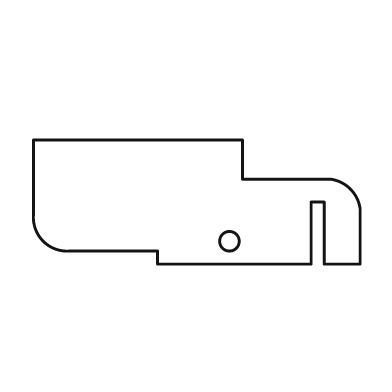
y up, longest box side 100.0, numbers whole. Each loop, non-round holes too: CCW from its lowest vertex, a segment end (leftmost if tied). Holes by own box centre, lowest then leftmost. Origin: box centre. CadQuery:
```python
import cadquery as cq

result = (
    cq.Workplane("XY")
    .moveTo(-12.0, -19.0)
    .lineTo(35.0, -19.0)
    .lineTo(35.0, 0.0)
    .lineTo(39.0, 0.0)
    .lineTo(39.0, -19.0)
    .lineTo(50.0, -19.0)
    .lineTo(50.0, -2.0)
    .threePointArc((47.0, 4.0), (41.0, 7.0))
    .lineTo(14.0, 7.0)
    .lineTo(14.0, 19.0)
    .lineTo(-50.0, 19.0)
    .lineTo(-50.0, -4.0)
    .threePointArc((-47.0, -12.0), (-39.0, -15.0))
    .lineTo(-12.0, -15.0)
    .close()
    .moveTo(10.0, -12.0)
    .circle(3.0)
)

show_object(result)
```